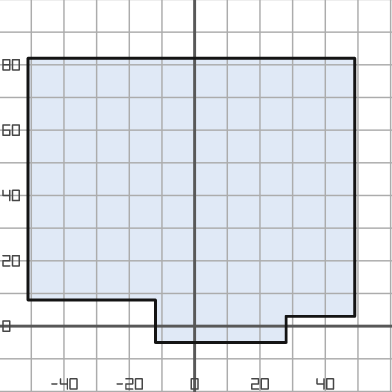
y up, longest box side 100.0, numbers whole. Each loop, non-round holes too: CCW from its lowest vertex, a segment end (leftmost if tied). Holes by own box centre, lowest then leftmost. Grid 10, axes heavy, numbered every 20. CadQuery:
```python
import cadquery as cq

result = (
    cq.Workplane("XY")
    .moveTo(-12.0, -5.0)
    .lineTo(28.0, -5.0)
    .lineTo(28.0, 3.0)
    .lineTo(49.0, 3.0)
    .lineTo(49.0, 82.0)
    .lineTo(-51.0, 82.0)
    .lineTo(-51.0, 8.0)
    .lineTo(-12.0, 8.0)
    .close()
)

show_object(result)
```